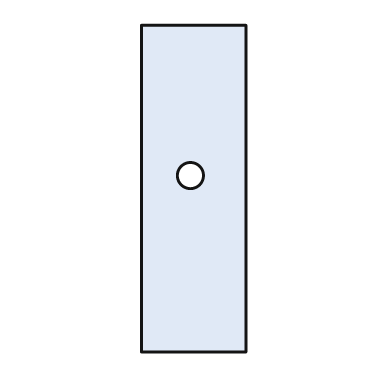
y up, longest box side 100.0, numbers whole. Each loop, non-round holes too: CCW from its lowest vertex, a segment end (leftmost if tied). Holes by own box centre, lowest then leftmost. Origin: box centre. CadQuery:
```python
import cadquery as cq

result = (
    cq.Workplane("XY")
    .moveTo(-16.0, -50.0)
    .lineTo(16.0, -50.0)
    .lineTo(16.0, 50.0)
    .lineTo(-16.0, 50.0)
    .close()
    .moveTo(-1.0, 4.0)
    .circle(4.0)
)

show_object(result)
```